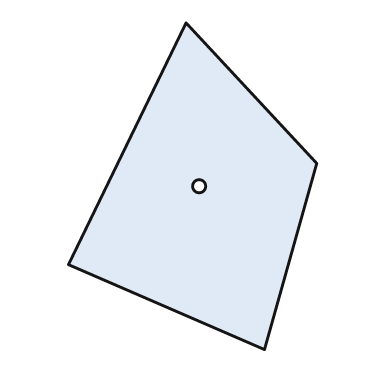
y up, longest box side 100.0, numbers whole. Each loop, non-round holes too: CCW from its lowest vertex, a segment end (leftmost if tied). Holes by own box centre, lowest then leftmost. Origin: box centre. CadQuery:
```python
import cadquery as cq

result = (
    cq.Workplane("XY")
    .moveTo(22.0, -50.0)
    .lineTo(38.0, 7.0)
    .lineTo(-2.0, 50.0)
    .lineTo(-38.0, -24.0)
    .close()
    .moveTo(2.0, 0.0)
    .circle(2.0)
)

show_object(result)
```